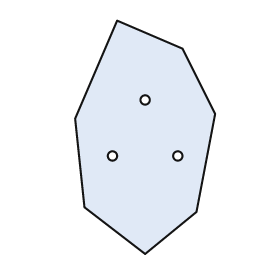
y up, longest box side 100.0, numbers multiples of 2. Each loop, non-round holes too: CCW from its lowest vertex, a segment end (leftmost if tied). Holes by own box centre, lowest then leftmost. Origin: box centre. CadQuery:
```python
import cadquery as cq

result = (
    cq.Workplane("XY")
    .moveTo(0.0, -50.0)
    .lineTo(22.0, -32.0)
    .lineTo(30.0, 10.0)
    .lineTo(16.0, 38.0)
    .lineTo(-12.0, 50.0)
    .lineTo(-30.0, 8.0)
    .lineTo(-26.0, -30.0)
    .close()
    .moveTo(-14.0, -8.0)
    .circle(2.0)
    .moveTo(14.0, -8.0)
    .circle(2.0)
    .moveTo(0.0, 16.0)
    .circle(2.0)
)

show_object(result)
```